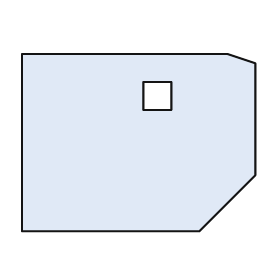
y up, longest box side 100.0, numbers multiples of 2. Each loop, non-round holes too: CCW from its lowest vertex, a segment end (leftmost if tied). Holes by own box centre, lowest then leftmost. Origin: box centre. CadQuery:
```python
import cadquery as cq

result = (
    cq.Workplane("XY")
    .moveTo(-50.0, -38.0)
    .lineTo(26.0, -38.0)
    .lineTo(50.0, -14.0)
    .lineTo(50.0, 34.0)
    .lineTo(38.0, 38.0)
    .lineTo(-50.0, 38.0)
    .close()
    .moveTo(2.0, 14.0)
    .lineTo(14.0, 14.0)
    .lineTo(14.0, 26.0)
    .lineTo(2.0, 26.0)
    .close()
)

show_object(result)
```